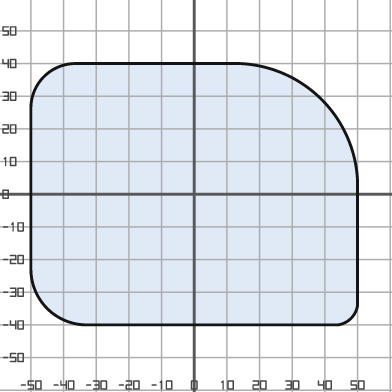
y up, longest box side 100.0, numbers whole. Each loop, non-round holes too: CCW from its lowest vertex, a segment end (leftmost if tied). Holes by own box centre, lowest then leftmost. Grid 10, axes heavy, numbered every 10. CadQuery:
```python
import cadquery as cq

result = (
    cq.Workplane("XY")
    .moveTo(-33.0, -40.0)
    .lineTo(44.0, -40.0)
    .threePointArc((48.0, -38.0), (50.0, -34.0))
    .lineTo(50.0, 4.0)
    .threePointArc((39.0, 29.0), (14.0, 40.0))
    .lineTo(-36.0, 40.0)
    .threePointArc((-46.0, 36.0), (-50.0, 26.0))
    .lineTo(-50.0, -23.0)
    .threePointArc((-45.0, -35.0), (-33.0, -40.0))
    .close()
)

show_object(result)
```